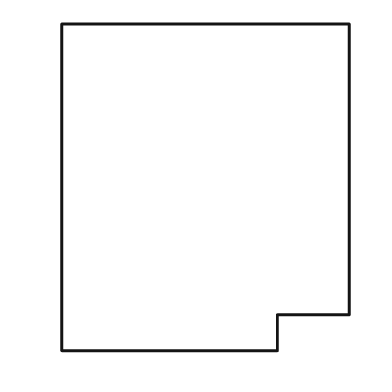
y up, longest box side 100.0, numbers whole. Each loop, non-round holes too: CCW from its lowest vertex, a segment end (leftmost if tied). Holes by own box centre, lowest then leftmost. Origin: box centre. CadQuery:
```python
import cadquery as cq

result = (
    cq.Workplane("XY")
    .moveTo(-44.0, -50.0)
    .lineTo(22.0, -50.0)
    .lineTo(22.0, -39.0)
    .lineTo(44.0, -39.0)
    .lineTo(44.0, 50.0)
    .lineTo(-44.0, 50.0)
    .close()
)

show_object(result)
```